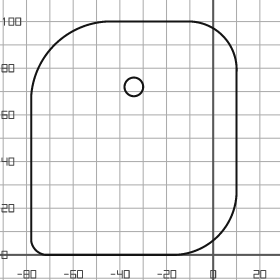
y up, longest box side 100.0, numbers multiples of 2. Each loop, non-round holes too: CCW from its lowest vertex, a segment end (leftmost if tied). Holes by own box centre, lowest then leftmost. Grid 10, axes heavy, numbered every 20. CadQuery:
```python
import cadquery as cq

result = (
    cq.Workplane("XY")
    .moveTo(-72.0, 0.0)
    .lineTo(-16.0, 0.0)
    .threePointArc((2.0, 8.0), (10.0, 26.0))
    .lineTo(10.0, 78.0)
    .threePointArc((4.0, 94.0), (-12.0, 100.0))
    .lineTo(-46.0, 100.0)
    .threePointArc((-68.0, 90.0), (-78.0, 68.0))
    .lineTo(-78.0, 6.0)
    .threePointArc((-76.0, 2.0), (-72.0, 0.0))
    .close()
    .moveTo(-34.0, 72.0)
    .circle(4.0)
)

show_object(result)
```